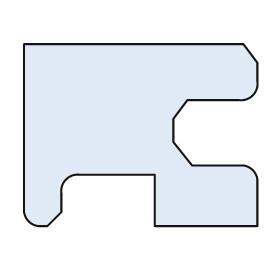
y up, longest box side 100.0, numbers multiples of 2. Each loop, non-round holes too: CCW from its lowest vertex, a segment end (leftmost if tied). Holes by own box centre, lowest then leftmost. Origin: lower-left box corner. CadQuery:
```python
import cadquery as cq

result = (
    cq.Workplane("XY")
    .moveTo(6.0, 0.0)
    .lineTo(10.0, 0.0)
    .lineTo(16.0, 6.0)
    .lineTo(16.0, 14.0)
    .threePointArc((18.0, 20.0), (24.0, 22.0))
    .lineTo(56.0, 22.0)
    .lineTo(56.0, 0.0)
    .lineTo(100.0, 0.0)
    .lineTo(100.0, 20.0)
    .threePointArc((98.0, 24.0), (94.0, 26.0))
    .lineTo(72.0, 26.0)
    .lineTo(64.0, 36.0)
    .lineTo(64.0, 46.0)
    .lineTo(70.0, 54.0)
    .lineTo(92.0, 54.0)
    .threePointArc((98.0, 56.0), (100.0, 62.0))
    .lineTo(100.0, 70.0)
    .lineTo(94.0, 78.0)
    .lineTo(0.0, 78.0)
    .lineTo(0.0, 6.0)
    .threePointArc((2.0, 2.0), (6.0, 0.0))
    .close()
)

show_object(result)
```